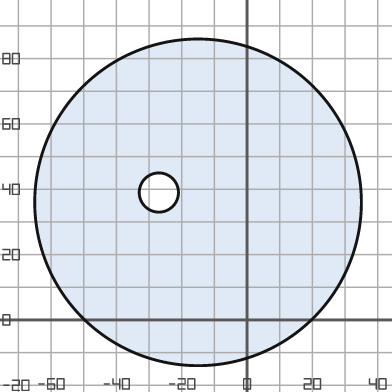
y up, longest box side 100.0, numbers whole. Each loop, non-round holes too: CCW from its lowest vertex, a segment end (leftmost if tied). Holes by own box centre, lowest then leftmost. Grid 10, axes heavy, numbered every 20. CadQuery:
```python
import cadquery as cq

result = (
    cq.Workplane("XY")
    .moveTo(-15.0, 36.0)
    .circle(50.0)
    .moveTo(-27.0, 39.0)
    .circle(6.0)
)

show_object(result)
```